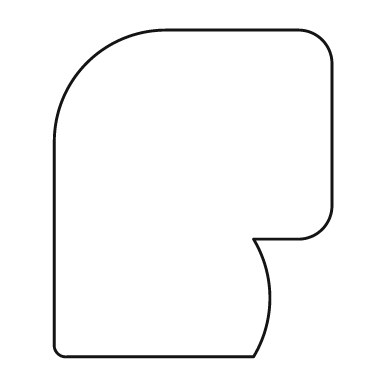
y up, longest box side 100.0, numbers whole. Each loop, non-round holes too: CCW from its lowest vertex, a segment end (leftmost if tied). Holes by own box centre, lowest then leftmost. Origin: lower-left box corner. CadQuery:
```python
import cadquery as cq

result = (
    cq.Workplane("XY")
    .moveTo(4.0, 0.0)
    .lineTo(61.0, 0.0)
    .threePointArc((66.0, 18.0), (61.0, 36.0))
    .lineTo(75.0, 36.0)
    .threePointArc((82.0, 39.0), (85.0, 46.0))
    .lineTo(85.0, 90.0)
    .threePointArc((82.0, 97.0), (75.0, 100.0))
    .lineTo(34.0, 100.0)
    .threePointArc((10.0, 90.0), (0.0, 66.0))
    .lineTo(0.0, 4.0)
    .threePointArc((1.0, 1.0), (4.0, 0.0))
    .close()
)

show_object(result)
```